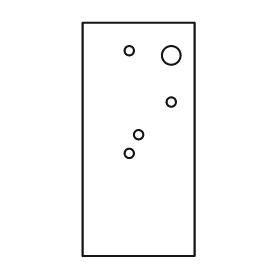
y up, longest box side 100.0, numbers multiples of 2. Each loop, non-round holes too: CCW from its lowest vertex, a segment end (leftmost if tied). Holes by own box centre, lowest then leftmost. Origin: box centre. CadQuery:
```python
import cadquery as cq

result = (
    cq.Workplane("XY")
    .moveTo(-24.0, -50.0)
    .lineTo(24.0, -50.0)
    .lineTo(24.0, 50.0)
    .lineTo(-24.0, 50.0)
    .close()
    .moveTo(-4.0, -6.0)
    .circle(2.0)
    .moveTo(0.0, 2.0)
    .circle(2.0)
    .moveTo(14.0, 16.0)
    .circle(2.0)
    .moveTo(14.0, 36.0)
    .circle(4.0)
    .moveTo(-4.0, 38.0)
    .circle(2.0)
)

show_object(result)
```